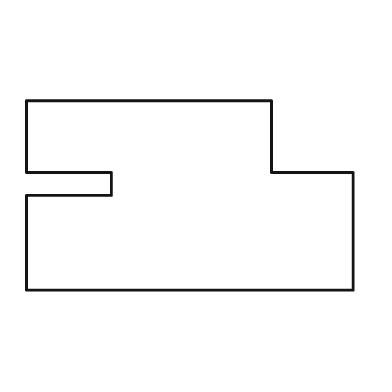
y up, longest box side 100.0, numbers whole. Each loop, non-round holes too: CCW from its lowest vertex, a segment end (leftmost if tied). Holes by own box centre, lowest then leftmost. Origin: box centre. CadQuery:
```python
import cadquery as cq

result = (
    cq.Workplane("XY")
    .moveTo(-50.0, -29.0)
    .lineTo(50.0, -29.0)
    .lineTo(50.0, 7.0)
    .lineTo(25.0, 7.0)
    .lineTo(25.0, 29.0)
    .lineTo(-50.0, 29.0)
    .lineTo(-50.0, 7.0)
    .lineTo(-24.0, 7.0)
    .lineTo(-24.0, 0.0)
    .lineTo(-50.0, 0.0)
    .close()
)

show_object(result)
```